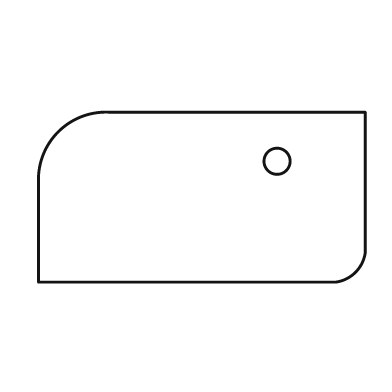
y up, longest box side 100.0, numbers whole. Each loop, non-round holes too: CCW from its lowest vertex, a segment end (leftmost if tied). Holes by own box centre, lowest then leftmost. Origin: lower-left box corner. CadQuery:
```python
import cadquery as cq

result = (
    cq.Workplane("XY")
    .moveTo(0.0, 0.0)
    .lineTo(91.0, 0.0)
    .threePointArc((97.0, 3.0), (100.0, 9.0))
    .lineTo(100.0, 52.0)
    .lineTo(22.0, 52.0)
    .threePointArc((6.0, 46.0), (0.0, 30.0))
    .close()
    .moveTo(73.0, 37.0)
    .circle(4.0)
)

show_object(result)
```